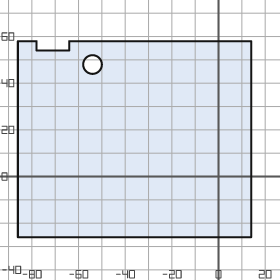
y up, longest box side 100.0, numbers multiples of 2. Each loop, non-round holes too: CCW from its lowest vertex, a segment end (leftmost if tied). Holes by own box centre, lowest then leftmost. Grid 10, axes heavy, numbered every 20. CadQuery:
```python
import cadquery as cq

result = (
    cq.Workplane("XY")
    .moveTo(-86.0, -26.0)
    .lineTo(14.0, -26.0)
    .lineTo(14.0, 58.0)
    .lineTo(-64.0, 58.0)
    .lineTo(-64.0, 54.0)
    .lineTo(-78.0, 54.0)
    .lineTo(-78.0, 58.0)
    .lineTo(-86.0, 58.0)
    .close()
    .moveTo(-54.0, 48.0)
    .circle(4.0)
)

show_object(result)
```